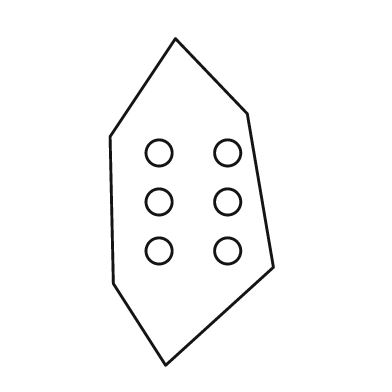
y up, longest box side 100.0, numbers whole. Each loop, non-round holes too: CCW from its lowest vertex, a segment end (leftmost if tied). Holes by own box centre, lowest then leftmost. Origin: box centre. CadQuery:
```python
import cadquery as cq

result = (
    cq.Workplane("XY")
    .moveTo(-8.0, -50.0)
    .lineTo(25.0, -20.0)
    .lineTo(17.0, 27.0)
    .lineTo(-5.0, 50.0)
    .lineTo(-25.0, 20.0)
    .lineTo(-24.0, -25.0)
    .close()
    .moveTo(-10.0, -15.0)
    .circle(4.0)
    .moveTo(11.0, -15.0)
    .circle(4.0)
    .moveTo(-10.0, 0.0)
    .circle(4.0)
    .moveTo(11.0, 0.0)
    .circle(4.0)
    .moveTo(-10.0, 15.0)
    .circle(4.0)
    .moveTo(11.0, 15.0)
    .circle(4.0)
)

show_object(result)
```